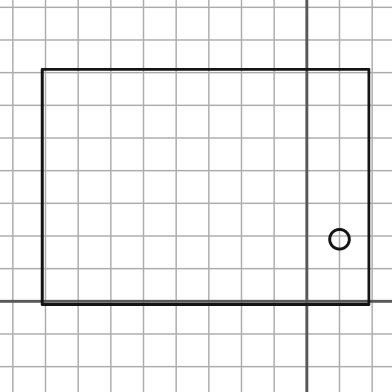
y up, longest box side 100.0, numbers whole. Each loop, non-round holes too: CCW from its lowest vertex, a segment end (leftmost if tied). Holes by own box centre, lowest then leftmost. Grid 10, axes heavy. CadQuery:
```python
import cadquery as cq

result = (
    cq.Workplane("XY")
    .moveTo(-81.0, -1.0)
    .lineTo(19.0, -1.0)
    .lineTo(19.0, 71.0)
    .lineTo(-81.0, 71.0)
    .close()
    .moveTo(10.0, 19.0)
    .circle(3.0)
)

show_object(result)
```